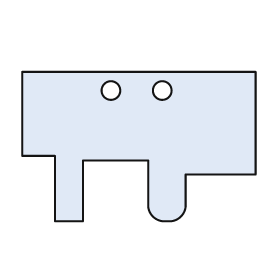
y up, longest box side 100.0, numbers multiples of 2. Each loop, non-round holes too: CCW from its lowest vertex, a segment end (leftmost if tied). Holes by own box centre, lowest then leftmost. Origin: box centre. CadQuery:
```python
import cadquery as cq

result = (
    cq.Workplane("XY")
    .moveTo(-36.0, -32.0)
    .lineTo(-24.0, -32.0)
    .lineTo(-24.0, -6.0)
    .lineTo(4.0, -6.0)
    .lineTo(4.0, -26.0)
    .threePointArc((6.0, -30.0), (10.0, -32.0))
    .lineTo(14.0, -32.0)
    .threePointArc((18.0, -30.0), (20.0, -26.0))
    .lineTo(20.0, -12.0)
    .lineTo(50.0, -12.0)
    .lineTo(50.0, 32.0)
    .lineTo(-50.0, 32.0)
    .lineTo(-50.0, -4.0)
    .lineTo(-36.0, -4.0)
    .close()
    .moveTo(-12.0, 24.0)
    .circle(4.0)
    .moveTo(10.0, 24.0)
    .circle(4.0)
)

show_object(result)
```